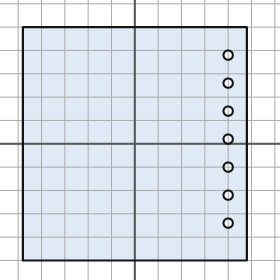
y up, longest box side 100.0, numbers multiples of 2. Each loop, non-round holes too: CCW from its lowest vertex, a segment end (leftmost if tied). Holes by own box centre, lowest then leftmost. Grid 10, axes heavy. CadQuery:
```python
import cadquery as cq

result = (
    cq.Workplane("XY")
    .moveTo(-48.0, -50.0)
    .lineTo(48.0, -50.0)
    .lineTo(48.0, 50.0)
    .lineTo(-48.0, 50.0)
    .close()
    .moveTo(40.0, -34.0)
    .circle(2.0)
    .moveTo(40.0, -22.0)
    .circle(2.0)
    .moveTo(40.0, -10.0)
    .circle(2.0)
    .moveTo(40.0, 2.0)
    .circle(2.0)
    .moveTo(40.0, 14.0)
    .circle(2.0)
    .moveTo(40.0, 26.0)
    .circle(2.0)
    .moveTo(40.0, 38.0)
    .circle(2.0)
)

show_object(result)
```